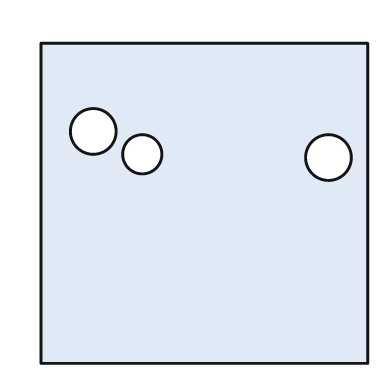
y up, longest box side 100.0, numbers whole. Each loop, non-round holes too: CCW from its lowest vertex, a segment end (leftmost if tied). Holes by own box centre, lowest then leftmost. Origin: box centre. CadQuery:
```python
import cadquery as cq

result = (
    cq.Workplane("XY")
    .moveTo(-50.0, -49.0)
    .lineTo(50.0, -49.0)
    .lineTo(50.0, 49.0)
    .lineTo(-50.0, 49.0)
    .close()
    .moveTo(38.0, 14.0)
    .circle(7.0)
    .moveTo(-19.0, 15.0)
    .circle(6.0)
    .moveTo(-34.0, 22.0)
    .circle(7.0)
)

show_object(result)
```